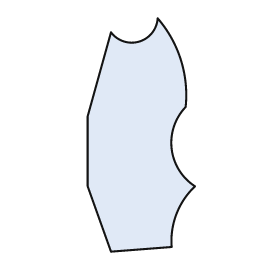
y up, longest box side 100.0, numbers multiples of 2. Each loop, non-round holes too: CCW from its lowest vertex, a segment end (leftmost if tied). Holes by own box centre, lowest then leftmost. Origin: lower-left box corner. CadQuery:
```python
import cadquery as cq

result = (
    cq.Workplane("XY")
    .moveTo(10.0, 0.0)
    .lineTo(36.0, 2.0)
    .threePointArc((38.0, 16.0), (46.0, 28.0))
    .threePointArc((36.0, 44.0), (42.0, 62.0))
    .threePointArc((40.0, 82.0), (30.0, 100.0))
    .threePointArc((22.0, 90.0), (10.0, 94.0))
    .lineTo(0.0, 58.0)
    .lineTo(0.0, 28.0)
    .close()
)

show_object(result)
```